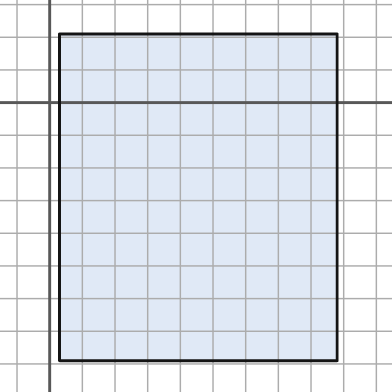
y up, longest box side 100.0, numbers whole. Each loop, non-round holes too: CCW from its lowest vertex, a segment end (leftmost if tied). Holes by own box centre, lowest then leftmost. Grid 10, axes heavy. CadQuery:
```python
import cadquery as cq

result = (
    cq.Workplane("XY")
    .moveTo(3.0, -79.0)
    .lineTo(88.0, -79.0)
    .lineTo(88.0, 21.0)
    .lineTo(3.0, 21.0)
    .close()
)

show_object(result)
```